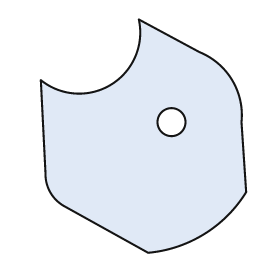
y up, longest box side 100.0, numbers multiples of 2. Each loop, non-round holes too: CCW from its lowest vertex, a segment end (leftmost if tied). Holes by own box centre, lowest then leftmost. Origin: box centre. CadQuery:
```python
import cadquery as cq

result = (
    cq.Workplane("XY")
    .moveTo(2.0, -50.0)
    .threePointArc((26.0, -42.0), (44.0, -24.0))
    .lineTo(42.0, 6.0)
    .threePointArc((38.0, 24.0), (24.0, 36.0))
    .lineTo(-2.0, 50.0)
    .threePointArc((-14.0, 22.0), (-44.0, 24.0))
    .lineTo(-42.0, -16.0)
    .threePointArc((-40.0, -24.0), (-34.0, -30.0))
    .close()
    .moveTo(12.0, 6.0)
    .circle(6.0)
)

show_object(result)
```